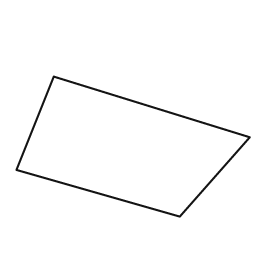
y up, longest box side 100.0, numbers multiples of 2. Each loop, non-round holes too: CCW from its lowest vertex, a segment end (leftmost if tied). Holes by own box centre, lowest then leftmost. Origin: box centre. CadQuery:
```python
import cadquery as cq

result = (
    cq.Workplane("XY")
    .moveTo(20.0, -30.0)
    .lineTo(50.0, 4.0)
    .lineTo(-34.0, 30.0)
    .lineTo(-50.0, -10.0)
    .close()
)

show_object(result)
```